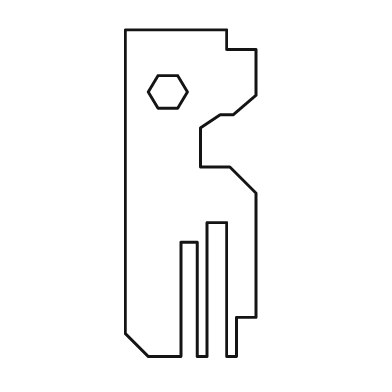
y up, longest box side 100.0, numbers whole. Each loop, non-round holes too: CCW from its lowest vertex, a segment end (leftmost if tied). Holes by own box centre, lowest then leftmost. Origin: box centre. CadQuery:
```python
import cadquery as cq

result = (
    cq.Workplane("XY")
    .moveTo(-13.0, -50.0)
    .lineTo(-3.0, -50.0)
    .lineTo(-3.0, -15.0)
    .lineTo(2.0, -15.0)
    .lineTo(2.0, -50.0)
    .lineTo(5.0, -50.0)
    .lineTo(5.0, -9.0)
    .lineTo(11.0, -9.0)
    .lineTo(11.0, -50.0)
    .lineTo(14.0, -50.0)
    .lineTo(14.0, -38.0)
    .lineTo(20.0, -38.0)
    .lineTo(20.0, 0.0)
    .lineTo(12.0, 8.0)
    .lineTo(3.0, 8.0)
    .lineTo(3.0, 20.0)
    .lineTo(9.0, 24.0)
    .lineTo(13.0, 24.0)
    .lineTo(20.0, 30.0)
    .lineTo(20.0, 44.0)
    .lineTo(11.0, 44.0)
    .lineTo(11.0, 50.0)
    .lineTo(-20.0, 50.0)
    .lineTo(-20.0, -43.0)
    .close()
    .moveTo(-10.0, 26.0)
    .lineTo(-4.0, 26.0)
    .lineTo(-1.0, 31.0)
    .lineTo(-4.0, 36.0)
    .lineTo(-10.0, 36.0)
    .lineTo(-13.0, 31.0)
    .close()
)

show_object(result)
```